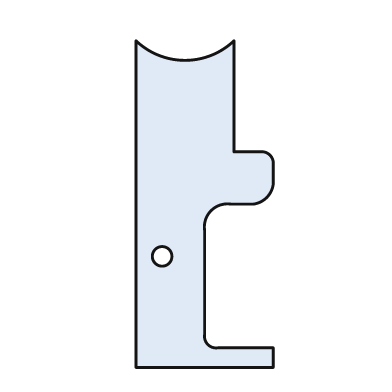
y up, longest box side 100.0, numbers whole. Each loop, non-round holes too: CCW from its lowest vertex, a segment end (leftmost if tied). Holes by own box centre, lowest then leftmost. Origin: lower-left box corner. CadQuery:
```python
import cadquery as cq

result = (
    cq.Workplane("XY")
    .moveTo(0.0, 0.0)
    .lineTo(42.0, 0.0)
    .lineTo(42.0, 6.0)
    .lineTo(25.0, 6.0)
    .threePointArc((22.0, 7.0), (21.0, 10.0))
    .lineTo(21.0, 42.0)
    .threePointArc((23.0, 48.0), (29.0, 50.0))
    .lineTo(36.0, 50.0)
    .threePointArc((40.0, 52.0), (42.0, 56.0))
    .lineTo(42.0, 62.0)
    .threePointArc((41.0, 65.0), (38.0, 66.0))
    .lineTo(30.0, 66.0)
    .lineTo(30.0, 100.0)
    .threePointArc((15.0, 94.0), (0.0, 100.0))
    .close()
    .moveTo(8.0, 34.0)
    .circle(3.0)
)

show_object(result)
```